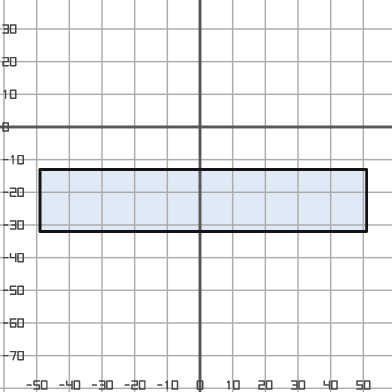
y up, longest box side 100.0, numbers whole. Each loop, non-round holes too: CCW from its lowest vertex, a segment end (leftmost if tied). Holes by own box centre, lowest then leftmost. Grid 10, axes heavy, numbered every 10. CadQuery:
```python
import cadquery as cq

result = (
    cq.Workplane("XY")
    .moveTo(-49.0, -32.0)
    .lineTo(51.0, -32.0)
    .lineTo(51.0, -13.0)
    .lineTo(-49.0, -13.0)
    .close()
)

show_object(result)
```